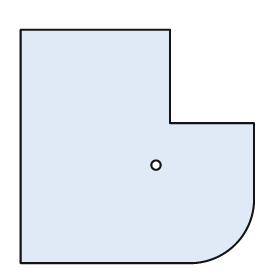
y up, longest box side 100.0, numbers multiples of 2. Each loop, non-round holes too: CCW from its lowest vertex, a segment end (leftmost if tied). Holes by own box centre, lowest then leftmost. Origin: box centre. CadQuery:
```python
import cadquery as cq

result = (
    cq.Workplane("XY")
    .moveTo(-50.0, -50.0)
    .lineTo(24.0, -50.0)
    .threePointArc((42.0, -42.0), (50.0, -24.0))
    .lineTo(50.0, 10.0)
    .lineTo(14.0, 10.0)
    .lineTo(14.0, 50.0)
    .lineTo(-50.0, 50.0)
    .close()
    .moveTo(8.0, -8.0)
    .circle(2.0)
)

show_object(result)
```